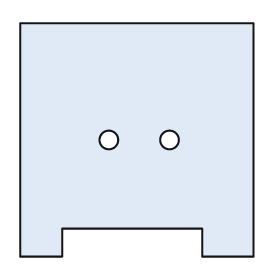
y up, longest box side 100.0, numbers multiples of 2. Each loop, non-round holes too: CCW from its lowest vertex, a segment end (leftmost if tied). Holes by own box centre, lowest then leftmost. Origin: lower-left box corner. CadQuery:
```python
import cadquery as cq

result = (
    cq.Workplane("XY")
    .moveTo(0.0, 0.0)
    .lineTo(18.0, 0.0)
    .lineTo(18.0, 12.0)
    .lineTo(78.0, 12.0)
    .lineTo(78.0, 0.0)
    .lineTo(100.0, 0.0)
    .lineTo(100.0, 100.0)
    .lineTo(0.0, 100.0)
    .close()
    .moveTo(38.0, 50.0)
    .circle(4.0)
    .moveTo(64.0, 50.0)
    .circle(4.0)
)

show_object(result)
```